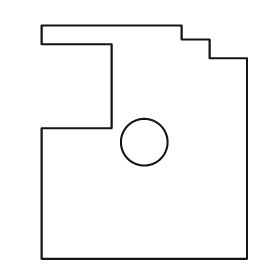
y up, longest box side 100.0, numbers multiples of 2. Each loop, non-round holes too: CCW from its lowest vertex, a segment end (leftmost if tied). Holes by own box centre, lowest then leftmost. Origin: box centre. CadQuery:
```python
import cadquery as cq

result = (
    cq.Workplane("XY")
    .moveTo(-44.0, -50.0)
    .lineTo(44.0, -50.0)
    .lineTo(44.0, 36.0)
    .lineTo(28.0, 36.0)
    .lineTo(28.0, 44.0)
    .lineTo(16.0, 44.0)
    .lineTo(16.0, 50.0)
    .lineTo(-44.0, 50.0)
    .lineTo(-44.0, 42.0)
    .lineTo(-14.0, 42.0)
    .lineTo(-14.0, 6.0)
    .lineTo(-44.0, 6.0)
    .close()
    .moveTo(0.0, 0.0)
    .circle(10.0)
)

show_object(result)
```